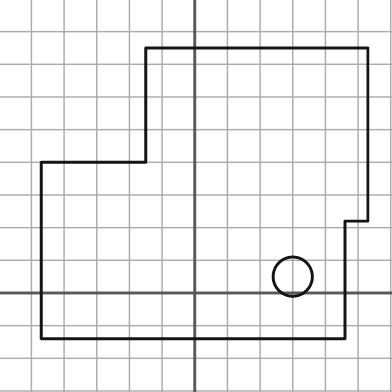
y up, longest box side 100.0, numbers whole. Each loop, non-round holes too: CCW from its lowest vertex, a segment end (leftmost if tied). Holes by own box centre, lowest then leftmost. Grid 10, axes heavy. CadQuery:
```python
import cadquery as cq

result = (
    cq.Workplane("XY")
    .moveTo(-47.0, -14.0)
    .lineTo(46.0, -14.0)
    .lineTo(46.0, 22.0)
    .lineTo(53.0, 22.0)
    .lineTo(53.0, 75.0)
    .lineTo(-15.0, 75.0)
    .lineTo(-15.0, 40.0)
    .lineTo(-47.0, 40.0)
    .close()
    .moveTo(30.0, 5.0)
    .circle(6.0)
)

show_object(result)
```